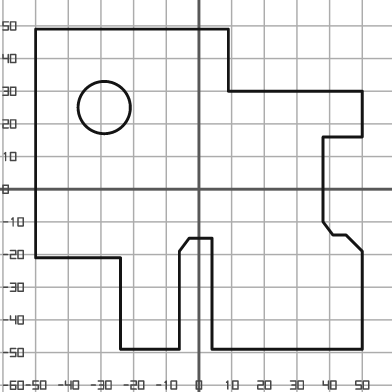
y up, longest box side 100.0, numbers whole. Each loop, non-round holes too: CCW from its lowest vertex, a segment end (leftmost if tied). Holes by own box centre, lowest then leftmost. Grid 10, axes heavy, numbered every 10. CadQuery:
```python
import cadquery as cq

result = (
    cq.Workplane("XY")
    .moveTo(-24.0, -49.0)
    .lineTo(-6.0, -49.0)
    .lineTo(-6.0, -19.0)
    .lineTo(-3.0, -15.0)
    .lineTo(4.0, -15.0)
    .lineTo(4.0, -49.0)
    .lineTo(50.0, -49.0)
    .lineTo(50.0, -19.0)
    .lineTo(45.0, -14.0)
    .lineTo(41.0, -14.0)
    .lineTo(38.0, -10.0)
    .lineTo(38.0, 16.0)
    .lineTo(50.0, 16.0)
    .lineTo(50.0, 30.0)
    .lineTo(9.0, 30.0)
    .lineTo(9.0, 49.0)
    .lineTo(-50.0, 49.0)
    .lineTo(-50.0, -21.0)
    .lineTo(-24.0, -21.0)
    .close()
    .moveTo(-29.0, 25.0)
    .circle(8.0)
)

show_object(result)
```